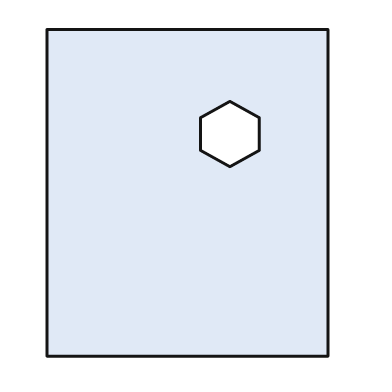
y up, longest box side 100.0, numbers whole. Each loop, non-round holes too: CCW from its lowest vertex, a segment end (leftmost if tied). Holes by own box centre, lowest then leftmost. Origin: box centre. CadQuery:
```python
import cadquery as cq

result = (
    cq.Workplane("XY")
    .moveTo(-43.0, -50.0)
    .lineTo(43.0, -50.0)
    .lineTo(43.0, 50.0)
    .lineTo(-43.0, 50.0)
    .close()
    .moveTo(13.0, 8.0)
    .lineTo(22.0, 13.0)
    .lineTo(22.0, 23.0)
    .lineTo(13.0, 28.0)
    .lineTo(4.0, 23.0)
    .lineTo(4.0, 13.0)
    .close()
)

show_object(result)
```